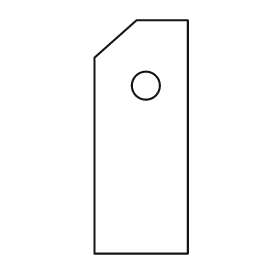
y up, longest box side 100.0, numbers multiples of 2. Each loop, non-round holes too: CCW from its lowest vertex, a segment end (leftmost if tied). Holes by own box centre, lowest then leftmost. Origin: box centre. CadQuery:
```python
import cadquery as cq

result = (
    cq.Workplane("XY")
    .moveTo(-20.0, -50.0)
    .lineTo(20.0, -50.0)
    .lineTo(20.0, 50.0)
    .lineTo(-2.0, 50.0)
    .lineTo(-20.0, 34.0)
    .close()
    .moveTo(2.0, 22.0)
    .circle(6.0)
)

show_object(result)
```